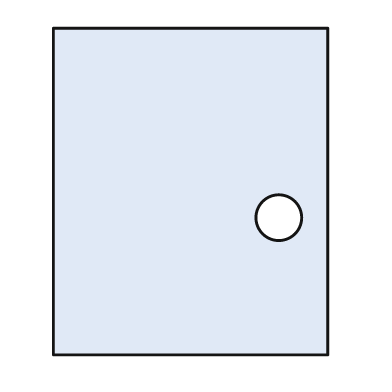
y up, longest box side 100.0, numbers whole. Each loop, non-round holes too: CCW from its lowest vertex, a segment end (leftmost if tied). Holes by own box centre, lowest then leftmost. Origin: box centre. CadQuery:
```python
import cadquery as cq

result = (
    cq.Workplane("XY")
    .moveTo(-42.0, -50.0)
    .lineTo(42.0, -50.0)
    .lineTo(42.0, 50.0)
    .lineTo(-42.0, 50.0)
    .close()
    .moveTo(27.0, -8.0)
    .circle(7.0)
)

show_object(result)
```